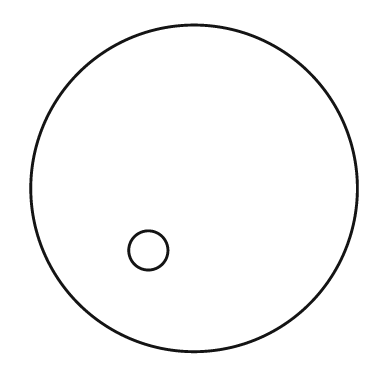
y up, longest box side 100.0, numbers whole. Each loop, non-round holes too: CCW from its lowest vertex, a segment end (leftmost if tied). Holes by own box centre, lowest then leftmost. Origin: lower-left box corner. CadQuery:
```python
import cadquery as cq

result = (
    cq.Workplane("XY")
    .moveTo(50.0, 50.0)
    .circle(50.0)
    .moveTo(36.0, 31.0)
    .circle(6.0)
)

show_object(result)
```